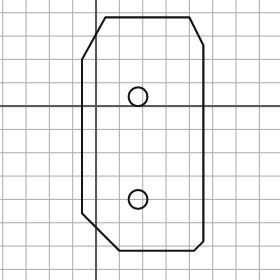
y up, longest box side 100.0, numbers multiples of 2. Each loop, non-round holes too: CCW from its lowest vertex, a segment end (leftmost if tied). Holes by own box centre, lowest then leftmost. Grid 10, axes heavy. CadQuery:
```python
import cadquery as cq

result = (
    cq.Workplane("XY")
    .moveTo(10.0, -62.0)
    .lineTo(42.0, -62.0)
    .lineTo(46.0, -58.0)
    .lineTo(46.0, 26.0)
    .lineTo(40.0, 38.0)
    .lineTo(4.0, 38.0)
    .lineTo(-6.0, 20.0)
    .lineTo(-6.0, -46.0)
    .close()
    .moveTo(18.0, -40.0)
    .circle(4.0)
    .moveTo(18.0, 4.0)
    .circle(4.0)
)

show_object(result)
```